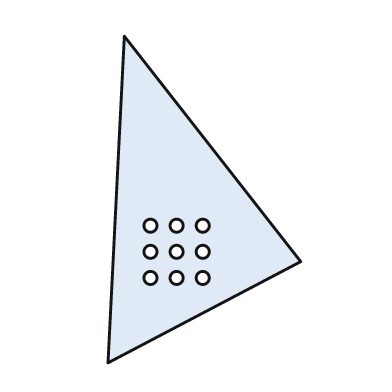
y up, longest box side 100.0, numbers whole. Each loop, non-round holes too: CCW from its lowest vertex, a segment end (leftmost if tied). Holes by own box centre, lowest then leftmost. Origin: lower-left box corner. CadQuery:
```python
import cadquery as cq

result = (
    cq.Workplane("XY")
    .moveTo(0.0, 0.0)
    .lineTo(59.0, 31.0)
    .lineTo(5.0, 100.0)
    .close()
    .moveTo(13.0, 26.0)
    .circle(2.0)
    .moveTo(21.0, 26.0)
    .circle(2.0)
    .moveTo(29.0, 26.0)
    .circle(2.0)
    .moveTo(13.0, 34.0)
    .circle(2.0)
    .moveTo(21.0, 34.0)
    .circle(2.0)
    .moveTo(29.0, 34.0)
    .circle(2.0)
    .moveTo(13.0, 42.0)
    .circle(2.0)
    .moveTo(21.0, 42.0)
    .circle(2.0)
    .moveTo(29.0, 42.0)
    .circle(2.0)
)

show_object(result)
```